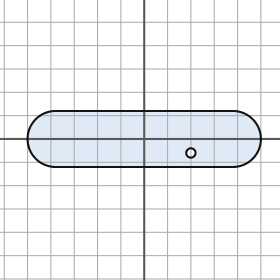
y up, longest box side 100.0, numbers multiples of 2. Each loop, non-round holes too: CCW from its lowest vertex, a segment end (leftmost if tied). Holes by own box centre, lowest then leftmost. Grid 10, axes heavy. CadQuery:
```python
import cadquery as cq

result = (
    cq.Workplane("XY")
    .moveTo(-38.0, -12.0)
    .lineTo(38.0, -12.0)
    .threePointArc((50.0, 0.0), (38.0, 12.0))
    .lineTo(-38.0, 12.0)
    .threePointArc((-50.0, 0.0), (-38.0, -12.0))
    .close()
    .moveTo(20.0, -6.0)
    .circle(2.0)
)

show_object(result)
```